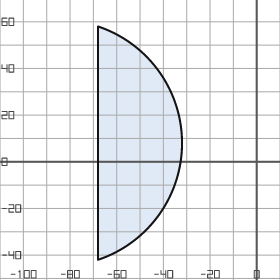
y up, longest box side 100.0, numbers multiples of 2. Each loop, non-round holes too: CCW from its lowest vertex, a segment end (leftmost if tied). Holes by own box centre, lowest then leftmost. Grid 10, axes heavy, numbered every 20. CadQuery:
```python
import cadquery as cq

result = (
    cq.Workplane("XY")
    .moveTo(-68.0, -42.0)
    .threePointArc((-32.0, 8.0), (-68.0, 58.0))
    .close()
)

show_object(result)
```